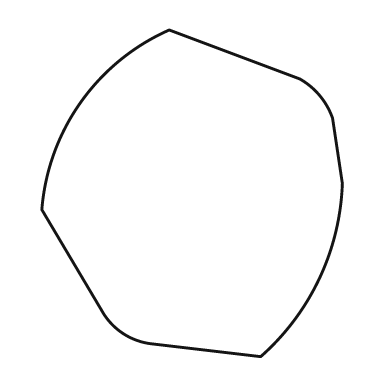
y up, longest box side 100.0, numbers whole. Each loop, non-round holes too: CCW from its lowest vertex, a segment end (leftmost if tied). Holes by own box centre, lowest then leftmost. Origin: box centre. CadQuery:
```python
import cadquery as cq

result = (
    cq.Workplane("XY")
    .moveTo(21.0, -50.0)
    .threePointArc((39.0, -26.0), (46.0, 3.0))
    .lineTo(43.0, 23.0)
    .threePointArc((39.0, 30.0), (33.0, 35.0))
    .lineTo(-7.0, 50.0)
    .threePointArc((-34.0, 28.0), (-46.0, -5.0))
    .lineTo(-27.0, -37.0)
    .threePointArc((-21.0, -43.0), (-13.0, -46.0))
    .close()
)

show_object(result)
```